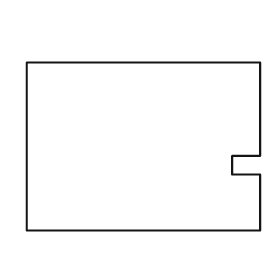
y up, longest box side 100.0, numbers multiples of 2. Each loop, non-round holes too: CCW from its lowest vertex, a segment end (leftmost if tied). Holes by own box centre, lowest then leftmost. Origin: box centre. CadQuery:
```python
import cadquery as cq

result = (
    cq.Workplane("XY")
    .moveTo(-50.0, -36.0)
    .lineTo(50.0, -36.0)
    .lineTo(50.0, -12.0)
    .lineTo(38.0, -12.0)
    .lineTo(38.0, -4.0)
    .lineTo(50.0, -4.0)
    .lineTo(50.0, 36.0)
    .lineTo(-50.0, 36.0)
    .close()
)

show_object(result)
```